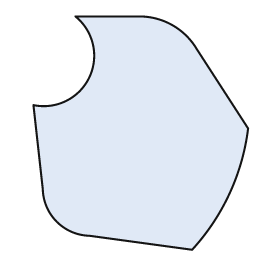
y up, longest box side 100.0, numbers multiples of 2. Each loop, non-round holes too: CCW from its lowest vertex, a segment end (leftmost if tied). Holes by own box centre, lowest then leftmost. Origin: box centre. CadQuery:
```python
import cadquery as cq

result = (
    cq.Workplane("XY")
    .moveTo(22.0, -50.0)
    .threePointArc((38.0, -26.0), (46.0, 2.0))
    .lineTo(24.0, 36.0)
    .threePointArc((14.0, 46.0), (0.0, 50.0))
    .lineTo(-28.0, 50.0)
    .threePointArc((-22.0, 24.0), (-46.0, 12.0))
    .lineTo(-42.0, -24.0)
    .threePointArc((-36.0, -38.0), (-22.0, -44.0))
    .close()
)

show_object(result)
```